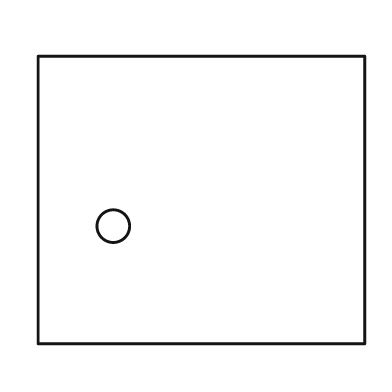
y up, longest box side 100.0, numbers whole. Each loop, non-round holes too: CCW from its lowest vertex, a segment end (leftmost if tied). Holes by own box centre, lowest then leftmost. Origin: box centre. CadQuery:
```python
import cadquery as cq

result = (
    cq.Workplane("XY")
    .moveTo(-50.0, -44.0)
    .lineTo(50.0, -44.0)
    .lineTo(50.0, 44.0)
    .lineTo(-50.0, 44.0)
    .close()
    .moveTo(-27.0, -8.0)
    .circle(5.0)
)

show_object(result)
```